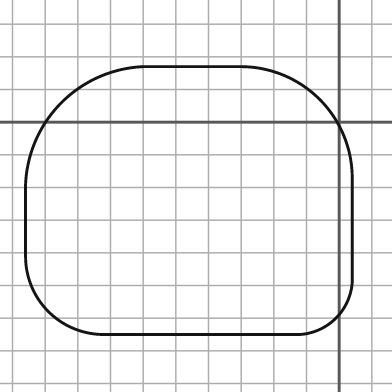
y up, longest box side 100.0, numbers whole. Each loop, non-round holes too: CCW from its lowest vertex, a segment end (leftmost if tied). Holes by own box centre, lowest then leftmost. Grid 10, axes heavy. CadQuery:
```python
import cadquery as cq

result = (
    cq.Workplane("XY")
    .moveTo(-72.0, -65.0)
    .lineTo(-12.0, -65.0)
    .threePointArc((-1.0, -60.0), (4.0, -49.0))
    .lineTo(4.0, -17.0)
    .threePointArc((-6.0, 7.0), (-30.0, 17.0))
    .lineTo(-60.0, 17.0)
    .threePointArc((-85.0, 6.0), (-96.0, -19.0))
    .lineTo(-96.0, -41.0)
    .threePointArc((-89.0, -58.0), (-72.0, -65.0))
    .close()
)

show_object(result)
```